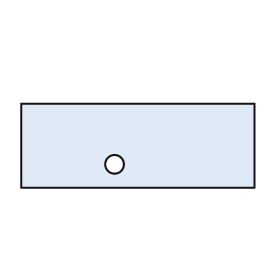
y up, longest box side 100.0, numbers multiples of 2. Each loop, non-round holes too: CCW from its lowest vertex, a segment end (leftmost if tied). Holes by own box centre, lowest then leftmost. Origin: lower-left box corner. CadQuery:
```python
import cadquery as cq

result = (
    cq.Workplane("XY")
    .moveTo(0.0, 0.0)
    .lineTo(100.0, 0.0)
    .lineTo(100.0, 36.0)
    .lineTo(0.0, 36.0)
    .close()
    .moveTo(40.0, 10.0)
    .circle(4.0)
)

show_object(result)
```